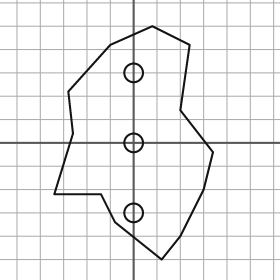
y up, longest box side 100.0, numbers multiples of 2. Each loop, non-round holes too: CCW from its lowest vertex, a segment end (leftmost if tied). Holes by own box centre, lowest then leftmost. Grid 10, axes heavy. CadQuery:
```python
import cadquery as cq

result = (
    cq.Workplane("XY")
    .moveTo(12.0, -50.0)
    .lineTo(20.0, -40.0)
    .lineTo(30.0, -20.0)
    .lineTo(34.0, -4.0)
    .lineTo(20.0, 14.0)
    .lineTo(24.0, 42.0)
    .lineTo(8.0, 50.0)
    .lineTo(-10.0, 42.0)
    .lineTo(-28.0, 22.0)
    .lineTo(-26.0, 4.0)
    .lineTo(-34.0, -22.0)
    .lineTo(-14.0, -22.0)
    .lineTo(-8.0, -34.0)
    .close()
    .moveTo(0.0, -30.0)
    .circle(4.0)
    .moveTo(0.0, 0.0)
    .circle(4.0)
    .moveTo(0.0, 30.0)
    .circle(4.0)
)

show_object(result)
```